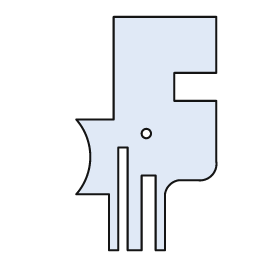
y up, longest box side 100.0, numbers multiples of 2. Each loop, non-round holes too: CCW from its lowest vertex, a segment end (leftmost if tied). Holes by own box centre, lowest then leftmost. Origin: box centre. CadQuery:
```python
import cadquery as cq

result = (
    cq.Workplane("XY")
    .moveTo(-16.0, -50.0)
    .lineTo(-12.0, -50.0)
    .lineTo(-12.0, -6.0)
    .lineTo(-8.0, -6.0)
    .lineTo(-8.0, -50.0)
    .lineTo(-2.0, -50.0)
    .lineTo(-2.0, -18.0)
    .lineTo(4.0, -18.0)
    .lineTo(4.0, -50.0)
    .lineTo(8.0, -50.0)
    .lineTo(8.0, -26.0)
    .threePointArc((10.0, -22.0), (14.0, -20.0))
    .lineTo(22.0, -20.0)
    .threePointArc((28.0, -18.0), (30.0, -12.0))
    .lineTo(30.0, 14.0)
    .lineTo(12.0, 14.0)
    .lineTo(12.0, 26.0)
    .lineTo(30.0, 26.0)
    .lineTo(30.0, 50.0)
    .lineTo(-14.0, 50.0)
    .lineTo(-14.0, 6.0)
    .lineTo(-30.0, 6.0)
    .threePointArc((-24.0, -10.0), (-30.0, -26.0))
    .lineTo(-16.0, -26.0)
    .close()
    .moveTo(0.0, 0.0)
    .circle(2.0)
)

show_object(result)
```